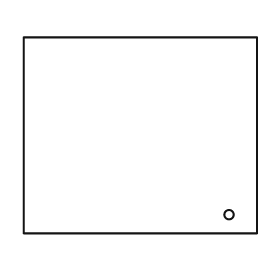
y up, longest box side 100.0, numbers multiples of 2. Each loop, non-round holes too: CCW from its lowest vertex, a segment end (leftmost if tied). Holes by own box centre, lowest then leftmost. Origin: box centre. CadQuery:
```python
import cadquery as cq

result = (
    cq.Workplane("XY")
    .moveTo(-50.0, -42.0)
    .lineTo(50.0, -42.0)
    .lineTo(50.0, 42.0)
    .lineTo(-50.0, 42.0)
    .close()
    .moveTo(38.0, -34.0)
    .circle(2.0)
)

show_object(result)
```